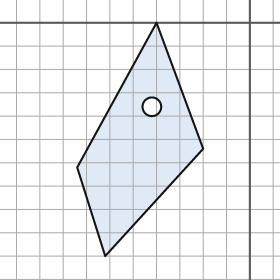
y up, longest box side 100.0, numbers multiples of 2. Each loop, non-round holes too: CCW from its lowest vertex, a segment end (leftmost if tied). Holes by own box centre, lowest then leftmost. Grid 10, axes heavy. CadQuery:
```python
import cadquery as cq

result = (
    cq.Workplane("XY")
    .moveTo(-62.0, -100.0)
    .lineTo(-20.0, -54.0)
    .lineTo(-40.0, 0.0)
    .lineTo(-74.0, -62.0)
    .close()
    .moveTo(-42.0, -36.0)
    .circle(4.0)
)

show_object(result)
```